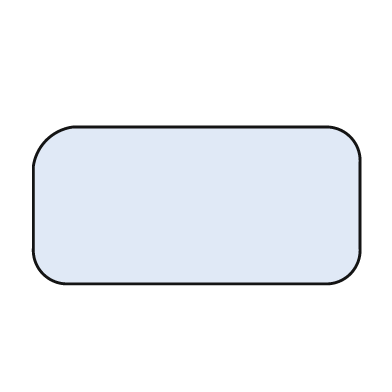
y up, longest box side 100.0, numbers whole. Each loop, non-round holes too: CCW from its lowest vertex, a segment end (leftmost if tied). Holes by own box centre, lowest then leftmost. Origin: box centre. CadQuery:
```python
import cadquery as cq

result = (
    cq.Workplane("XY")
    .moveTo(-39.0, -24.0)
    .lineTo(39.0, -24.0)
    .threePointArc((47.0, -21.0), (50.0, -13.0))
    .lineTo(50.0, 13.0)
    .threePointArc((47.0, 21.0), (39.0, 24.0))
    .lineTo(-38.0, 24.0)
    .threePointArc((-46.0, 20.0), (-50.0, 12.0))
    .lineTo(-50.0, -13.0)
    .threePointArc((-47.0, -21.0), (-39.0, -24.0))
    .close()
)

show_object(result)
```